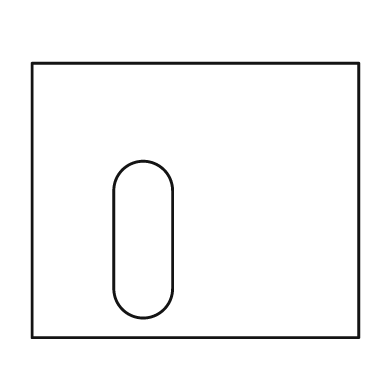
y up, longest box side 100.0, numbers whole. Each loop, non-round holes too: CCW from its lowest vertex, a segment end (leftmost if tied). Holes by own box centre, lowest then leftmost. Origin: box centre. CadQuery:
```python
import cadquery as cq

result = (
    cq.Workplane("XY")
    .moveTo(-50.0, -42.0)
    .lineTo(50.0, -42.0)
    .lineTo(50.0, 42.0)
    .lineTo(-50.0, 42.0)
    .close()
    .moveTo(-25.0, -27.0)
    .threePointArc((-16.0, -36.0), (-7.0, -27.0))
    .lineTo(-7.0, 3.0)
    .threePointArc((-16.0, 12.0), (-25.0, 3.0))
    .close()
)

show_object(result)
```